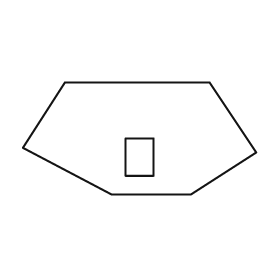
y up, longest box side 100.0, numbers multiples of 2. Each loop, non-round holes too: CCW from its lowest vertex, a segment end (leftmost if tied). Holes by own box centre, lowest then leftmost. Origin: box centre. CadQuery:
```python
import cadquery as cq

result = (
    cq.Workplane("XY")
    .moveTo(-12.0, -24.0)
    .lineTo(22.0, -24.0)
    .lineTo(50.0, -6.0)
    .lineTo(30.0, 24.0)
    .lineTo(-32.0, 24.0)
    .lineTo(-50.0, -4.0)
    .close()
    .moveTo(-6.0, -16.0)
    .lineTo(6.0, -16.0)
    .lineTo(6.0, 0.0)
    .lineTo(-6.0, 0.0)
    .close()
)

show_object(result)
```